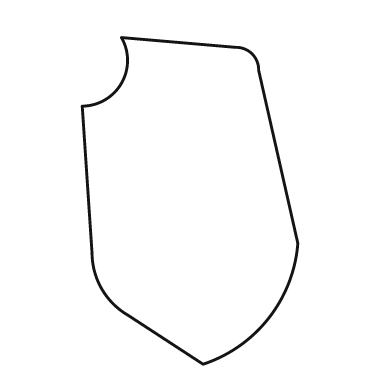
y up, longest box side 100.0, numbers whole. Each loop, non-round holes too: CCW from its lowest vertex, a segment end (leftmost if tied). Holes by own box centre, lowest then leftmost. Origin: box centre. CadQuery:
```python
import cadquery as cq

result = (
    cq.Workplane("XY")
    .moveTo(4.0, -50.0)
    .threePointArc((24.0, -36.0), (33.0, -13.0))
    .lineTo(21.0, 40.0)
    .threePointArc((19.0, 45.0), (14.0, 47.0))
    .lineTo(-21.0, 50.0)
    .threePointArc((-21.0, 36.0), (-33.0, 29.0))
    .lineTo(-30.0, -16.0)
    .threePointArc((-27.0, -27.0), (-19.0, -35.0))
    .close()
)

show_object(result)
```